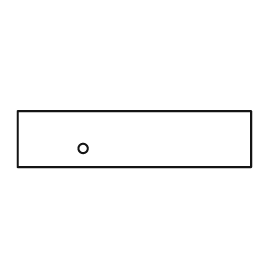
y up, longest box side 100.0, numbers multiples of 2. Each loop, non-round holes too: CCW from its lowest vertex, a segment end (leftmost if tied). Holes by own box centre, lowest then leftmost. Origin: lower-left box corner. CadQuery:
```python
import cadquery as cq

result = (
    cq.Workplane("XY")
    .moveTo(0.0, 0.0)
    .lineTo(100.0, 0.0)
    .lineTo(100.0, 24.0)
    .lineTo(0.0, 24.0)
    .close()
    .moveTo(28.0, 8.0)
    .circle(2.0)
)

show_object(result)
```